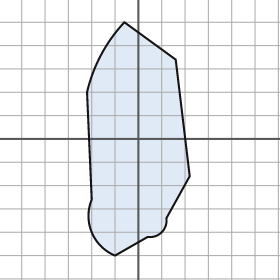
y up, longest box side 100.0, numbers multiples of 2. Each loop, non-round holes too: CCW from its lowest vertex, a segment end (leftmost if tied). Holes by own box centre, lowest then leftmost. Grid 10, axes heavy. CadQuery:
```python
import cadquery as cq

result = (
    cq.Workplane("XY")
    .moveTo(-10.0, -50.0)
    .lineTo(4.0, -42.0)
    .threePointArc((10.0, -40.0), (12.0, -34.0))
    .lineTo(22.0, -16.0)
    .lineTo(16.0, 34.0)
    .lineTo(-6.0, 50.0)
    .threePointArc((-16.0, 36.0), (-22.0, 20.0))
    .lineTo(-20.0, -26.0)
    .threePointArc((-20.0, -40.0), (-10.0, -50.0))
    .close()
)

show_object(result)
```